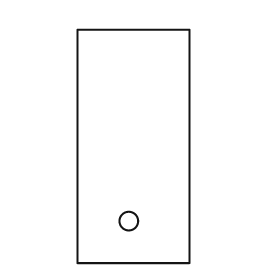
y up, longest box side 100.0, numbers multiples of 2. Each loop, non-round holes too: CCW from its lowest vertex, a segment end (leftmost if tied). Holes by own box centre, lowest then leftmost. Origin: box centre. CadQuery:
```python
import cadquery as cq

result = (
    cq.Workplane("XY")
    .moveTo(-24.0, -50.0)
    .lineTo(24.0, -50.0)
    .lineTo(24.0, 50.0)
    .lineTo(-24.0, 50.0)
    .close()
    .moveTo(-2.0, -32.0)
    .circle(4.0)
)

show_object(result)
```